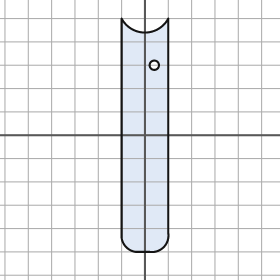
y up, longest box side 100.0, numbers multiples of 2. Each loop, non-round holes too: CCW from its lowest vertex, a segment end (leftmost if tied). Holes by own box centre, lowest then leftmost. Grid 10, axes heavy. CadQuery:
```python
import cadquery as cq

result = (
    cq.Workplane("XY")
    .moveTo(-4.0, -50.0)
    .lineTo(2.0, -50.0)
    .threePointArc((8.0, -48.0), (10.0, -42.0))
    .lineTo(10.0, 50.0)
    .threePointArc((0.0, 44.0), (-10.0, 50.0))
    .lineTo(-10.0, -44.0)
    .threePointArc((-8.0, -48.0), (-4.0, -50.0))
    .close()
    .moveTo(4.0, 30.0)
    .circle(2.0)
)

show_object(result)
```